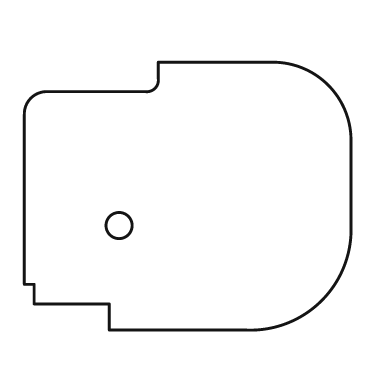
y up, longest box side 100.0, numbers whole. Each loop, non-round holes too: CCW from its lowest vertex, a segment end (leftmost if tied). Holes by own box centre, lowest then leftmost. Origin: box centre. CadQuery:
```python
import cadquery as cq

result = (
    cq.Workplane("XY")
    .moveTo(-24.0, -41.0)
    .lineTo(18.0, -41.0)
    .threePointArc((41.0, -32.0), (50.0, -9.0))
    .lineTo(50.0, 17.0)
    .threePointArc((43.0, 34.0), (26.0, 41.0))
    .lineTo(-9.0, 41.0)
    .lineTo(-9.0, 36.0)
    .threePointArc((-10.0, 33.0), (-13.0, 32.0))
    .lineTo(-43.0, 32.0)
    .threePointArc((-48.0, 30.0), (-50.0, 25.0))
    .lineTo(-50.0, -27.0)
    .lineTo(-47.0, -27.0)
    .lineTo(-47.0, -33.0)
    .lineTo(-24.0, -33.0)
    .close()
    .moveTo(-21.0, -9.0)
    .circle(4.0)
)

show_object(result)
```